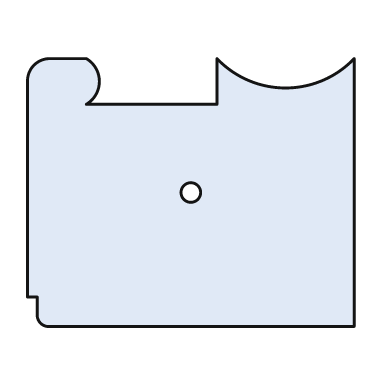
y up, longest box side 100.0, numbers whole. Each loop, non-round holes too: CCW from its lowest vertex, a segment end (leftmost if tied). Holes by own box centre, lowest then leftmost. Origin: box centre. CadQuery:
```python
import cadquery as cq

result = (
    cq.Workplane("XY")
    .moveTo(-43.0, -41.0)
    .lineTo(50.0, -41.0)
    .lineTo(50.0, 41.0)
    .threePointArc((29.0, 32.0), (8.0, 41.0))
    .lineTo(8.0, 27.0)
    .lineTo(-32.0, 27.0)
    .threePointArc((-28.0, 34.0), (-32.0, 41.0))
    .lineTo(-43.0, 41.0)
    .threePointArc((-48.0, 39.0), (-50.0, 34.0))
    .lineTo(-50.0, -32.0)
    .lineTo(-47.0, -32.0)
    .lineTo(-47.0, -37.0)
    .threePointArc((-46.0, -40.0), (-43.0, -41.0))
    .close()
    .moveTo(0.0, 0.0)
    .circle(3.0)
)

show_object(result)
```